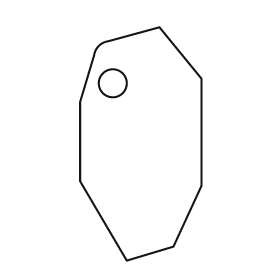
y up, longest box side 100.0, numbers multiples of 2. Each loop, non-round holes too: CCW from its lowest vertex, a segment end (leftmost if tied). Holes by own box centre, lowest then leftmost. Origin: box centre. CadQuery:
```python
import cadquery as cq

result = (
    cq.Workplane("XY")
    .moveTo(-6.0, -50.0)
    .lineTo(14.0, -44.0)
    .lineTo(26.0, -18.0)
    .lineTo(26.0, 28.0)
    .lineTo(8.0, 50.0)
    .lineTo(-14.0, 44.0)
    .threePointArc((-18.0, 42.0), (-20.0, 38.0))
    .lineTo(-26.0, 18.0)
    .lineTo(-26.0, -16.0)
    .close()
    .moveTo(-12.0, 26.0)
    .circle(6.0)
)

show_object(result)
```